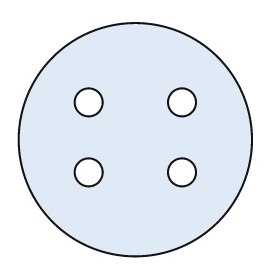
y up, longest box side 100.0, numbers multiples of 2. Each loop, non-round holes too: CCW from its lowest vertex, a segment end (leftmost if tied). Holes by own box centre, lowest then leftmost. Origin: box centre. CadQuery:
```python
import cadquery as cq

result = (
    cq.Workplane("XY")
    .moveTo(0.0, 0.0)
    .circle(50.0)
    .moveTo(-20.0, -14.0)
    .circle(6.0)
    .moveTo(20.0, -14.0)
    .circle(6.0)
    .moveTo(-20.0, 16.0)
    .circle(6.0)
    .moveTo(20.0, 16.0)
    .circle(6.0)
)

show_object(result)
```